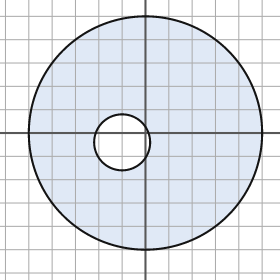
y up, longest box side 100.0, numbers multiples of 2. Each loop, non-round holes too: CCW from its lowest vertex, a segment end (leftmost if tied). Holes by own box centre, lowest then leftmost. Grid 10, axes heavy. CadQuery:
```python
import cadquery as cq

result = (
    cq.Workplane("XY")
    .moveTo(0.0, 0.0)
    .circle(50.0)
    .moveTo(-10.0, -4.0)
    .circle(12.0)
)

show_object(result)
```